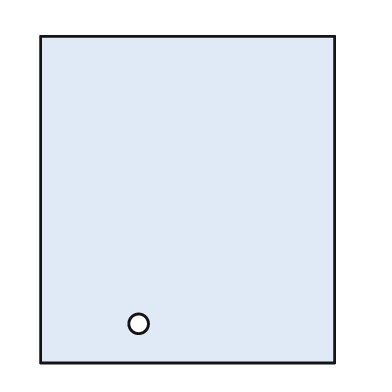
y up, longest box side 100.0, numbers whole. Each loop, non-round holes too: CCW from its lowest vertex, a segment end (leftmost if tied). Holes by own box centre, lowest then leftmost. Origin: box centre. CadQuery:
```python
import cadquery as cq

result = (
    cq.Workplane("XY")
    .moveTo(-45.0, -50.0)
    .lineTo(45.0, -50.0)
    .lineTo(45.0, 50.0)
    .lineTo(-45.0, 50.0)
    .close()
    .moveTo(-15.0, -38.0)
    .circle(3.0)
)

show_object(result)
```